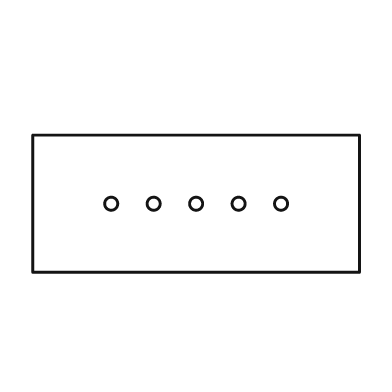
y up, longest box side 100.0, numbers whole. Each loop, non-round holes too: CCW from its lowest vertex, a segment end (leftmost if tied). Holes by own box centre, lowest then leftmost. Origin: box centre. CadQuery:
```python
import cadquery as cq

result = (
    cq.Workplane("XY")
    .moveTo(-50.0, -21.0)
    .lineTo(50.0, -21.0)
    .lineTo(50.0, 21.0)
    .lineTo(-50.0, 21.0)
    .close()
    .moveTo(-26.0, 0.0)
    .circle(2.0)
    .moveTo(-13.0, 0.0)
    .circle(2.0)
    .moveTo(0.0, 0.0)
    .circle(2.0)
    .moveTo(13.0, 0.0)
    .circle(2.0)
    .moveTo(26.0, 0.0)
    .circle(2.0)
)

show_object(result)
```